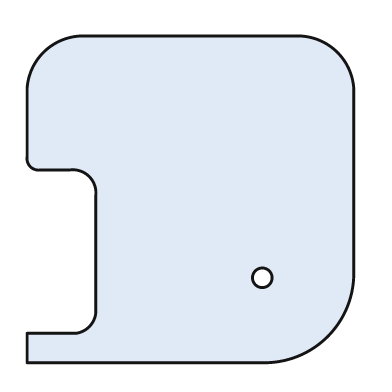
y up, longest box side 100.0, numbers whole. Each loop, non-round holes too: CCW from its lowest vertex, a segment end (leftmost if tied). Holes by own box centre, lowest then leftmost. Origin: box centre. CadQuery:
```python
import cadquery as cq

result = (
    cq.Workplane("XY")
    .moveTo(-50.0, -50.0)
    .lineTo(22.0, -50.0)
    .threePointArc((42.0, -42.0), (50.0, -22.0))
    .lineTo(50.0, 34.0)
    .threePointArc((45.0, 45.0), (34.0, 50.0))
    .lineTo(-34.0, 50.0)
    .threePointArc((-45.0, 45.0), (-50.0, 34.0))
    .lineTo(-50.0, 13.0)
    .threePointArc((-49.0, 10.0), (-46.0, 9.0))
    .lineTo(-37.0, 9.0)
    .threePointArc((-31.0, 7.0), (-29.0, 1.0))
    .lineTo(-29.0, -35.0)
    .threePointArc((-31.0, -39.0), (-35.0, -41.0))
    .lineTo(-50.0, -41.0)
    .close()
    .moveTo(22.0, -24.0)
    .circle(3.0)
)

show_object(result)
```